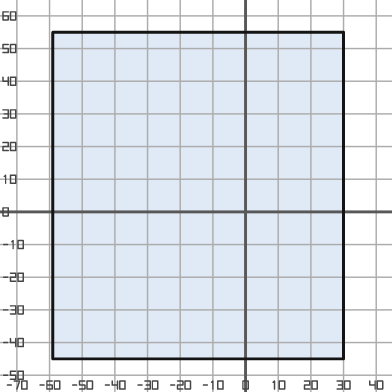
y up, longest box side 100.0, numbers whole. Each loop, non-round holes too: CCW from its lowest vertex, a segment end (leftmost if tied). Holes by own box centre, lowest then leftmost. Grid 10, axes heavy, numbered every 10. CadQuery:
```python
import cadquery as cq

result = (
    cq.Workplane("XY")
    .moveTo(-59.0, -45.0)
    .lineTo(30.0, -45.0)
    .lineTo(30.0, 55.0)
    .lineTo(-59.0, 55.0)
    .close()
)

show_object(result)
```